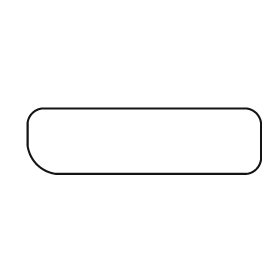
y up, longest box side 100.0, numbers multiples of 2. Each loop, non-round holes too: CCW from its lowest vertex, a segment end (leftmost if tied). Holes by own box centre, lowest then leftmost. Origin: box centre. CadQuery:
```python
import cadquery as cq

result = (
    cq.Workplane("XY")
    .moveTo(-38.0, -14.0)
    .lineTo(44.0, -14.0)
    .threePointArc((48.0, -12.0), (50.0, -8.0))
    .lineTo(50.0, 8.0)
    .threePointArc((48.0, 12.0), (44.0, 14.0))
    .lineTo(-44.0, 14.0)
    .threePointArc((-48.0, 12.0), (-50.0, 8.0))
    .lineTo(-50.0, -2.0)
    .threePointArc((-46.0, -10.0), (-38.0, -14.0))
    .close()
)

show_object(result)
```